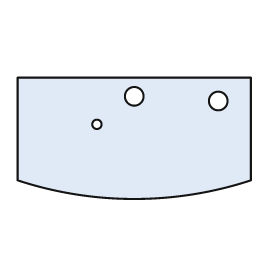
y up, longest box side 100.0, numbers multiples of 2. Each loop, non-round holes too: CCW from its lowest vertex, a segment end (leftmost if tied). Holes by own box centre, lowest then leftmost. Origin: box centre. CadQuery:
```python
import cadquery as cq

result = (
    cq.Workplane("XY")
    .moveTo(-50.0, -18.0)
    .threePointArc((0.0, -26.0), (50.0, -18.0))
    .lineTo(50.0, 26.0)
    .lineTo(-50.0, 26.0)
    .close()
    .moveTo(-16.0, 6.0)
    .circle(2.0)
    .moveTo(36.0, 16.0)
    .circle(4.0)
    .moveTo(0.0, 18.0)
    .circle(4.0)
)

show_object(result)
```